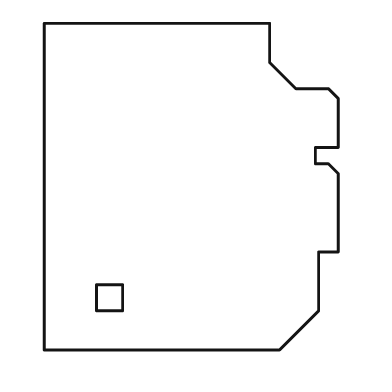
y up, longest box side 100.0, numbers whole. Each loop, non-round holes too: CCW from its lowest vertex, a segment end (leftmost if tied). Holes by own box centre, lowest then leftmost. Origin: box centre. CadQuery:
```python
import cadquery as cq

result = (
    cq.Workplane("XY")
    .moveTo(-45.0, -50.0)
    .lineTo(27.0, -50.0)
    .lineTo(39.0, -38.0)
    .lineTo(39.0, -20.0)
    .lineTo(45.0, -20.0)
    .lineTo(45.0, 4.0)
    .lineTo(42.0, 7.0)
    .lineTo(38.0, 7.0)
    .lineTo(38.0, 12.0)
    .lineTo(45.0, 12.0)
    .lineTo(45.0, 27.0)
    .lineTo(42.0, 30.0)
    .lineTo(32.0, 30.0)
    .lineTo(24.0, 38.0)
    .lineTo(24.0, 50.0)
    .lineTo(-45.0, 50.0)
    .close()
    .moveTo(-29.0, -38.0)
    .lineTo(-21.0, -38.0)
    .lineTo(-21.0, -30.0)
    .lineTo(-29.0, -30.0)
    .close()
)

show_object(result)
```